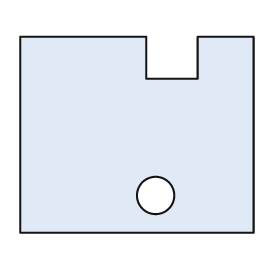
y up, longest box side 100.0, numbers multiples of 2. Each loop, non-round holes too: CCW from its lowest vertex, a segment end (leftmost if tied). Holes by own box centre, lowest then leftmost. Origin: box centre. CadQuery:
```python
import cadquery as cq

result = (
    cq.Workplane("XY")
    .moveTo(-50.0, -42.0)
    .lineTo(50.0, -42.0)
    .lineTo(50.0, 42.0)
    .lineTo(26.0, 42.0)
    .lineTo(26.0, 24.0)
    .lineTo(4.0, 24.0)
    .lineTo(4.0, 42.0)
    .lineTo(-50.0, 42.0)
    .close()
    .moveTo(8.0, -26.0)
    .circle(8.0)
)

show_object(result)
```